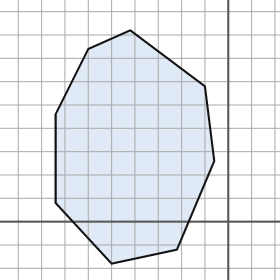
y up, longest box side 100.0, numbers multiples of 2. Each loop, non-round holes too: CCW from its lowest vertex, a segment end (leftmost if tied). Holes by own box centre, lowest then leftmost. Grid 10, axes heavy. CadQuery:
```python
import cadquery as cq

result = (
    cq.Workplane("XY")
    .moveTo(-50.0, -18.0)
    .lineTo(-22.0, -12.0)
    .lineTo(-6.0, 26.0)
    .lineTo(-10.0, 58.0)
    .lineTo(-42.0, 82.0)
    .lineTo(-60.0, 74.0)
    .lineTo(-74.0, 46.0)
    .lineTo(-74.0, 8.0)
    .close()
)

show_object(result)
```